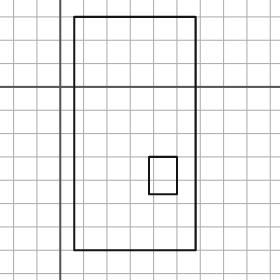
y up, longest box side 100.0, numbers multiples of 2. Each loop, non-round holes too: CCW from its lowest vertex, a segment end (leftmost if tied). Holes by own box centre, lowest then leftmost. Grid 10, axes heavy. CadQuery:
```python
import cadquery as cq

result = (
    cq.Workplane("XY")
    .moveTo(6.0, -70.0)
    .lineTo(58.0, -70.0)
    .lineTo(58.0, 30.0)
    .lineTo(6.0, 30.0)
    .close()
    .moveTo(38.0, -46.0)
    .lineTo(50.0, -46.0)
    .lineTo(50.0, -30.0)
    .lineTo(38.0, -30.0)
    .close()
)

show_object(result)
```